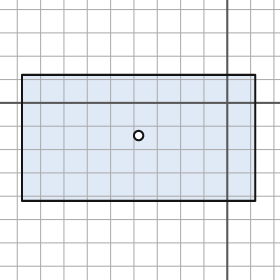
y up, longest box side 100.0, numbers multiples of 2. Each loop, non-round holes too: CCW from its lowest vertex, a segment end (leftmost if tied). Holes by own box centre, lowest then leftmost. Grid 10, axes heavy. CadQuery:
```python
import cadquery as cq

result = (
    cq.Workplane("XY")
    .moveTo(-88.0, -42.0)
    .lineTo(12.0, -42.0)
    .lineTo(12.0, 12.0)
    .lineTo(-88.0, 12.0)
    .close()
    .moveTo(-38.0, -14.0)
    .circle(2.0)
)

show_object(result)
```